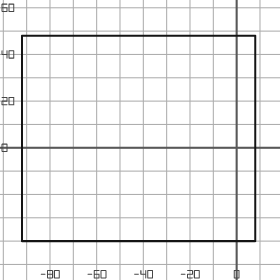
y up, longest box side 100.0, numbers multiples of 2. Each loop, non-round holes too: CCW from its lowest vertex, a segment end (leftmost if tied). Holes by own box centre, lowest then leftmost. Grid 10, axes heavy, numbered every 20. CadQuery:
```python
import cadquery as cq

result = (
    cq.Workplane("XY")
    .moveTo(-92.0, -40.0)
    .lineTo(8.0, -40.0)
    .lineTo(8.0, 48.0)
    .lineTo(-92.0, 48.0)
    .close()
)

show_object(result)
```